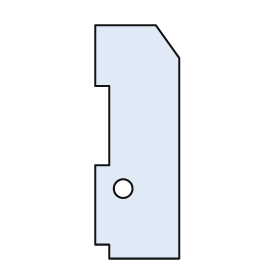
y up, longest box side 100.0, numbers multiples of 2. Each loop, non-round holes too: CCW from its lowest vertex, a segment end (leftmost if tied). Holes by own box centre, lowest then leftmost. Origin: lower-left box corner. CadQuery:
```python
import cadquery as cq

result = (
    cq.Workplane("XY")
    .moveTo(6.0, 0.0)
    .lineTo(36.0, 0.0)
    .lineTo(36.0, 86.0)
    .lineTo(26.0, 100.0)
    .lineTo(0.0, 100.0)
    .lineTo(0.0, 74.0)
    .lineTo(6.0, 74.0)
    .lineTo(6.0, 40.0)
    .lineTo(0.0, 40.0)
    .lineTo(0.0, 6.0)
    .lineTo(6.0, 6.0)
    .close()
    .moveTo(12.0, 30.0)
    .circle(4.0)
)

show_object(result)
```